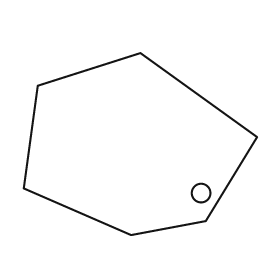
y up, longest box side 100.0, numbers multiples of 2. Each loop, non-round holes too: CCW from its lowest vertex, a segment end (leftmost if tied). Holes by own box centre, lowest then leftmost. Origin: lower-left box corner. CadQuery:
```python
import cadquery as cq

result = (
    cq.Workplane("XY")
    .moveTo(46.0, 0.0)
    .lineTo(78.0, 6.0)
    .lineTo(100.0, 42.0)
    .lineTo(50.0, 78.0)
    .lineTo(6.0, 64.0)
    .lineTo(0.0, 20.0)
    .close()
    .moveTo(76.0, 18.0)
    .circle(4.0)
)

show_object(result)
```